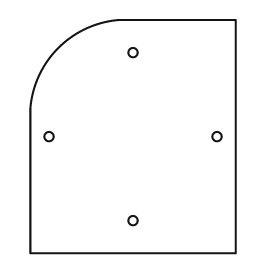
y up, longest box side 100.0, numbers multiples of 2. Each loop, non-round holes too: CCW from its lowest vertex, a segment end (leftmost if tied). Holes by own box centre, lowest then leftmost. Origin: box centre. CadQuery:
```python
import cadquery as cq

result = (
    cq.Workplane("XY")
    .moveTo(-44.0, -50.0)
    .lineTo(44.0, -50.0)
    .lineTo(44.0, 50.0)
    .lineTo(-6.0, 50.0)
    .threePointArc((-32.0, 38.0), (-44.0, 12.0))
    .close()
    .moveTo(0.0, -36.0)
    .circle(2.0)
    .moveTo(-36.0, 0.0)
    .circle(2.0)
    .moveTo(36.0, 0.0)
    .circle(2.0)
    .moveTo(0.0, 36.0)
    .circle(2.0)
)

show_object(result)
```